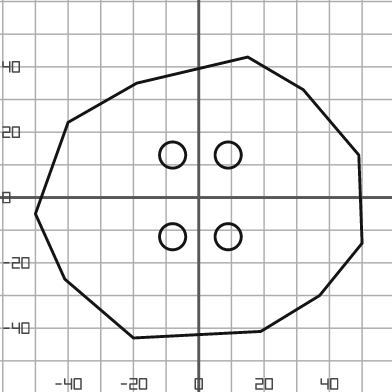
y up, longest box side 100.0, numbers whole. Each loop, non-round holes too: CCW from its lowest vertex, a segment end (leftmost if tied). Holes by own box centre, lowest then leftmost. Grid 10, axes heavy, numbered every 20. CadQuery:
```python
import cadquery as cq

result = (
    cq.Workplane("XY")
    .moveTo(-20.0, -43.0)
    .lineTo(19.0, -41.0)
    .lineTo(37.0, -30.0)
    .lineTo(50.0, -14.0)
    .lineTo(49.0, 13.0)
    .lineTo(32.0, 33.0)
    .lineTo(15.0, 43.0)
    .lineTo(-19.0, 35.0)
    .lineTo(-40.0, 23.0)
    .lineTo(-50.0, -5.0)
    .lineTo(-41.0, -25.0)
    .close()
    .moveTo(-8.0, -12.0)
    .circle(4.0)
    .moveTo(9.0, -12.0)
    .circle(4.0)
    .moveTo(-8.0, 13.0)
    .circle(4.0)
    .moveTo(9.0, 13.0)
    .circle(4.0)
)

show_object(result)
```